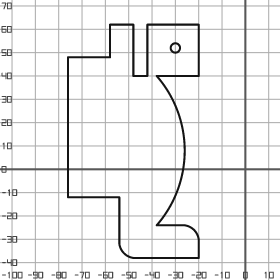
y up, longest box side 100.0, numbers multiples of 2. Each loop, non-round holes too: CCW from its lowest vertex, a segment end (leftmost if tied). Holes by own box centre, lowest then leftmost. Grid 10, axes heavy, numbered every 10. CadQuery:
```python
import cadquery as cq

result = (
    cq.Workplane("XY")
    .moveTo(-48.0, -38.0)
    .lineTo(-20.0, -38.0)
    .lineTo(-20.0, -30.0)
    .threePointArc((-22.0, -26.0), (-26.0, -24.0))
    .lineTo(-38.0, -24.0)
    .threePointArc((-26.0, 8.0), (-38.0, 40.0))
    .lineTo(-20.0, 40.0)
    .lineTo(-20.0, 62.0)
    .lineTo(-42.0, 62.0)
    .lineTo(-42.0, 40.0)
    .lineTo(-48.0, 40.0)
    .lineTo(-48.0, 62.0)
    .lineTo(-58.0, 62.0)
    .lineTo(-58.0, 48.0)
    .lineTo(-76.0, 48.0)
    .lineTo(-76.0, -12.0)
    .lineTo(-54.0, -12.0)
    .lineTo(-54.0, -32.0)
    .threePointArc((-52.0, -36.0), (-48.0, -38.0))
    .close()
    .moveTo(-30.0, 52.0)
    .circle(2.0)
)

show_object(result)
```